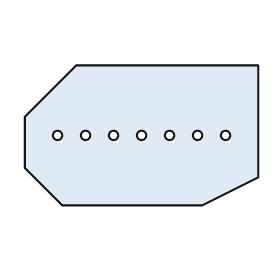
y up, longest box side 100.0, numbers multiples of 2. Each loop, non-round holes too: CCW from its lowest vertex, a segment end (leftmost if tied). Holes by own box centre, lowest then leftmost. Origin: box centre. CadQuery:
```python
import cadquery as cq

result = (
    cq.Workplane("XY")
    .moveTo(-34.0, -30.0)
    .lineTo(26.0, -30.0)
    .lineTo(50.0, -18.0)
    .lineTo(50.0, 30.0)
    .lineTo(-28.0, 30.0)
    .lineTo(-50.0, 8.0)
    .lineTo(-50.0, -14.0)
    .close()
    .moveTo(-36.0, 0.0)
    .circle(2.0)
    .moveTo(-24.0, 0.0)
    .circle(2.0)
    .moveTo(-12.0, 0.0)
    .circle(2.0)
    .moveTo(0.0, 0.0)
    .circle(2.0)
    .moveTo(12.0, 0.0)
    .circle(2.0)
    .moveTo(24.0, 0.0)
    .circle(2.0)
    .moveTo(36.0, 0.0)
    .circle(2.0)
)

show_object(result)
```